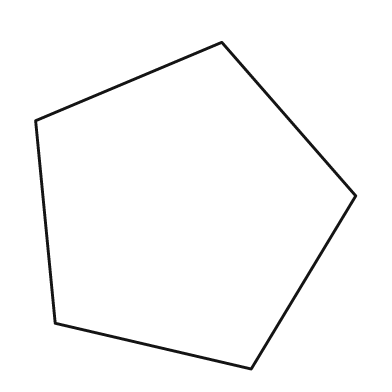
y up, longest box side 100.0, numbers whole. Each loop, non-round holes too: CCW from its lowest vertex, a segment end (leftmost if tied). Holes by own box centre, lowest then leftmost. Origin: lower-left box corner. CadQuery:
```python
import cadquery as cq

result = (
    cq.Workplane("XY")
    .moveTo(66.0, 0.0)
    .lineTo(98.0, 53.0)
    .lineTo(57.0, 100.0)
    .lineTo(0.0, 76.0)
    .lineTo(6.0, 14.0)
    .close()
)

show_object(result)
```